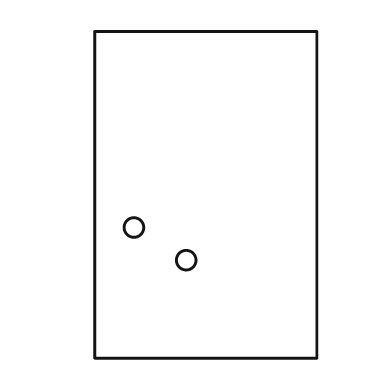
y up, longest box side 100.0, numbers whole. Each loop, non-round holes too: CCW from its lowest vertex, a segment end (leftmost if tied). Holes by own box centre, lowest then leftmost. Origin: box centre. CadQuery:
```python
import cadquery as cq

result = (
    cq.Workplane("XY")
    .moveTo(-34.0, -50.0)
    .lineTo(34.0, -50.0)
    .lineTo(34.0, 50.0)
    .lineTo(-34.0, 50.0)
    .close()
    .moveTo(-6.0, -20.0)
    .circle(3.0)
    .moveTo(-22.0, -10.0)
    .circle(3.0)
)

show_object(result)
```